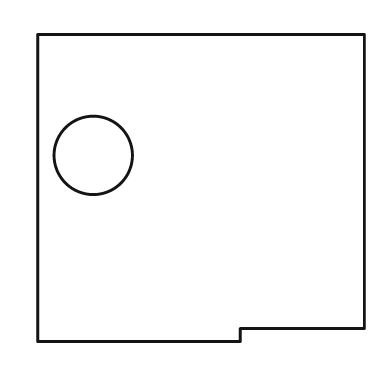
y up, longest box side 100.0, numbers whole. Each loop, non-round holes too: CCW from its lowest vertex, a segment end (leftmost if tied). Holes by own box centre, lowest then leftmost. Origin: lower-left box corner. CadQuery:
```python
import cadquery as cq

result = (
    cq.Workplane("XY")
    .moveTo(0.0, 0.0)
    .lineTo(62.0, 0.0)
    .lineTo(62.0, 4.0)
    .lineTo(100.0, 4.0)
    .lineTo(100.0, 94.0)
    .lineTo(0.0, 94.0)
    .close()
    .moveTo(17.0, 57.0)
    .circle(12.0)
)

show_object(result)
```